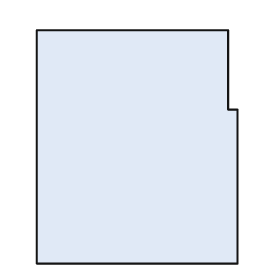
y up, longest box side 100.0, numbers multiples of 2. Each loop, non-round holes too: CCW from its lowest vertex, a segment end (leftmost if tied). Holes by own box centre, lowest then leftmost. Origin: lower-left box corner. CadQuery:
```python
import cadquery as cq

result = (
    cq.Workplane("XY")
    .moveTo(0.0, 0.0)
    .lineTo(86.0, 0.0)
    .lineTo(86.0, 66.0)
    .lineTo(82.0, 66.0)
    .lineTo(82.0, 100.0)
    .lineTo(0.0, 100.0)
    .close()
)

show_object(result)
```